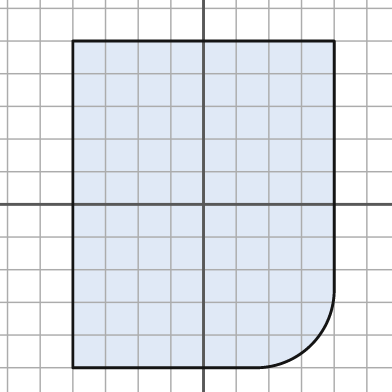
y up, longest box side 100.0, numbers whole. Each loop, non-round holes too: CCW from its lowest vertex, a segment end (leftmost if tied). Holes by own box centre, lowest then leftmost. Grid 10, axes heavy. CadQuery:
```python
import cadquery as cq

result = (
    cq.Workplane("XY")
    .moveTo(-40.0, -50.0)
    .lineTo(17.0, -50.0)
    .threePointArc((33.0, -43.0), (40.0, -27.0))
    .lineTo(40.0, 50.0)
    .lineTo(-40.0, 50.0)
    .close()
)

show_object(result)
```